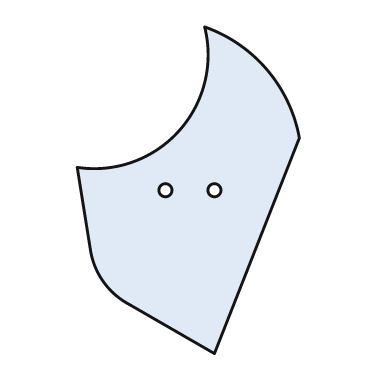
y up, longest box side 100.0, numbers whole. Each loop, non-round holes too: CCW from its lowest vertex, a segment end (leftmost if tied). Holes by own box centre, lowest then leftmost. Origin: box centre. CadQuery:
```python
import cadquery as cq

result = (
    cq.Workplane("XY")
    .moveTo(8.0, -50.0)
    .lineTo(34.0, 16.0)
    .threePointArc((24.0, 37.0), (5.0, 50.0))
    .threePointArc((-3.0, 18.0), (-34.0, 7.0))
    .lineTo(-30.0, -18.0)
    .threePointArc((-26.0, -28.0), (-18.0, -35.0))
    .close()
    .moveTo(-7.0, 0.0)
    .circle(2.0)
    .moveTo(8.0, 0.0)
    .circle(2.0)
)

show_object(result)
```